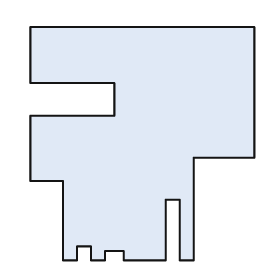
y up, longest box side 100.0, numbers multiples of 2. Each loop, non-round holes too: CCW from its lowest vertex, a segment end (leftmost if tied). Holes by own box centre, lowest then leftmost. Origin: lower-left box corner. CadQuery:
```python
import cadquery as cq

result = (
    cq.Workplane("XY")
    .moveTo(14.0, 0.0)
    .lineTo(20.0, 0.0)
    .lineTo(20.0, 6.0)
    .lineTo(26.0, 6.0)
    .lineTo(26.0, 0.0)
    .lineTo(32.0, 0.0)
    .lineTo(32.0, 4.0)
    .lineTo(40.0, 4.0)
    .lineTo(40.0, 0.0)
    .lineTo(58.0, 0.0)
    .lineTo(58.0, 26.0)
    .lineTo(64.0, 26.0)
    .lineTo(64.0, 0.0)
    .lineTo(70.0, 0.0)
    .lineTo(70.0, 44.0)
    .lineTo(96.0, 44.0)
    .lineTo(96.0, 100.0)
    .lineTo(0.0, 100.0)
    .lineTo(0.0, 76.0)
    .lineTo(36.0, 76.0)
    .lineTo(36.0, 62.0)
    .lineTo(0.0, 62.0)
    .lineTo(0.0, 34.0)
    .lineTo(14.0, 34.0)
    .close()
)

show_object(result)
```